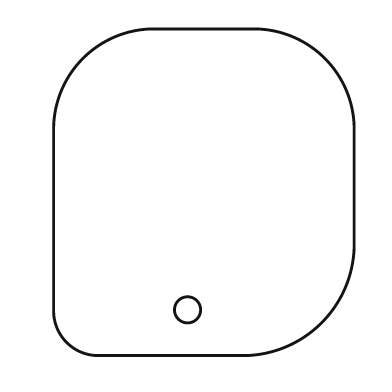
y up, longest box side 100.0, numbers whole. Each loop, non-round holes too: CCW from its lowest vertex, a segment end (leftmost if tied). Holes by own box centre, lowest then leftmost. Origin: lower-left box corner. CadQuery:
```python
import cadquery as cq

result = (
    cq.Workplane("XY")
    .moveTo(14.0, 0.0)
    .lineTo(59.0, 0.0)
    .threePointArc((82.0, 10.0), (92.0, 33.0))
    .lineTo(92.0, 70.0)
    .threePointArc((83.0, 91.0), (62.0, 100.0))
    .lineTo(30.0, 100.0)
    .threePointArc((9.0, 91.0), (0.0, 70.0))
    .lineTo(0.0, 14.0)
    .threePointArc((4.0, 4.0), (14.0, 0.0))
    .close()
    .moveTo(41.0, 14.0)
    .circle(4.0)
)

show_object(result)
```